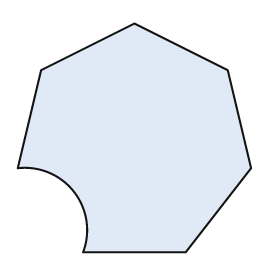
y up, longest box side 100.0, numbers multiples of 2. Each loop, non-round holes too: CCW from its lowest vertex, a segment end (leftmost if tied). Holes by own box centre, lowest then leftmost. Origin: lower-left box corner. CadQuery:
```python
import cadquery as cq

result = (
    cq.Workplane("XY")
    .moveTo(28.0, 0.0)
    .lineTo(72.0, 0.0)
    .lineTo(100.0, 36.0)
    .lineTo(90.0, 78.0)
    .lineTo(50.0, 98.0)
    .lineTo(10.0, 78.0)
    .lineTo(0.0, 36.0)
    .threePointArc((24.0, 26.0), (28.0, 0.0))
    .close()
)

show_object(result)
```